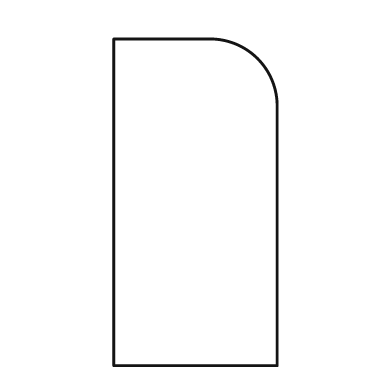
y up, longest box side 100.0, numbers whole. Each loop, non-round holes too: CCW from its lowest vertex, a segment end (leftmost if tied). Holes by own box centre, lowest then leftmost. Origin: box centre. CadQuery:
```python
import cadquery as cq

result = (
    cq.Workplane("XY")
    .moveTo(-25.0, -50.0)
    .lineTo(25.0, -50.0)
    .lineTo(25.0, 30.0)
    .threePointArc((19.0, 44.0), (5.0, 50.0))
    .lineTo(-25.0, 50.0)
    .close()
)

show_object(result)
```